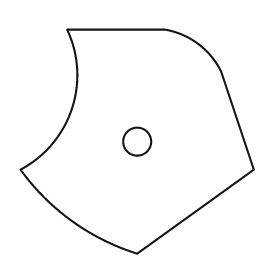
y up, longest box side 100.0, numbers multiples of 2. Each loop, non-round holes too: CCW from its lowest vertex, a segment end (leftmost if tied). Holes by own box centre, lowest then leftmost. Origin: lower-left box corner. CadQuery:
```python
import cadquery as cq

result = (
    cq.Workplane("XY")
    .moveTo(50.0, 0.0)
    .lineTo(100.0, 36.0)
    .lineTo(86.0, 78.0)
    .threePointArc((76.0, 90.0), (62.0, 96.0))
    .lineTo(20.0, 96.0)
    .threePointArc((22.0, 62.0), (0.0, 36.0))
    .threePointArc((22.0, 14.0), (50.0, 0.0))
    .close()
    .moveTo(50.0, 48.0)
    .circle(6.0)
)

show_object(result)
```